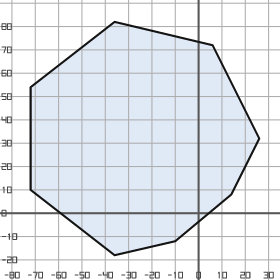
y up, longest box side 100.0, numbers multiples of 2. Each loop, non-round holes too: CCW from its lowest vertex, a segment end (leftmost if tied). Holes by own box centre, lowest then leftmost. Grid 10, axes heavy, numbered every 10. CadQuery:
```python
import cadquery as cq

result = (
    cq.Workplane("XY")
    .moveTo(-36.0, -18.0)
    .lineTo(-10.0, -12.0)
    .lineTo(14.0, 8.0)
    .lineTo(26.0, 32.0)
    .lineTo(6.0, 72.0)
    .lineTo(-36.0, 82.0)
    .lineTo(-72.0, 54.0)
    .lineTo(-72.0, 10.0)
    .close()
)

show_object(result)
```